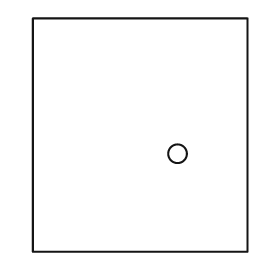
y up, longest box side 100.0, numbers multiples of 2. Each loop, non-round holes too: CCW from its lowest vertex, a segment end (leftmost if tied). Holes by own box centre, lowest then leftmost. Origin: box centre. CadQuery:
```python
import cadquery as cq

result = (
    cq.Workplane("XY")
    .moveTo(-46.0, -50.0)
    .lineTo(46.0, -50.0)
    .lineTo(46.0, 50.0)
    .lineTo(-46.0, 50.0)
    .close()
    .moveTo(16.0, -8.0)
    .circle(4.0)
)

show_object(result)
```